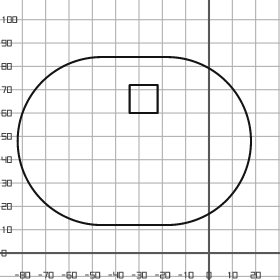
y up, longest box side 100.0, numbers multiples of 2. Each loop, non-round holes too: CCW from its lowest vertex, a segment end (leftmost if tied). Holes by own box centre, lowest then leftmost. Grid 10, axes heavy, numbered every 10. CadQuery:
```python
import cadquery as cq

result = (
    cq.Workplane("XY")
    .moveTo(-46.0, 12.0)
    .lineTo(-18.0, 12.0)
    .threePointArc((18.0, 48.0), (-18.0, 84.0))
    .lineTo(-46.0, 84.0)
    .threePointArc((-82.0, 48.0), (-46.0, 12.0))
    .close()
    .moveTo(-34.0, 60.0)
    .lineTo(-22.0, 60.0)
    .lineTo(-22.0, 72.0)
    .lineTo(-34.0, 72.0)
    .close()
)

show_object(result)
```